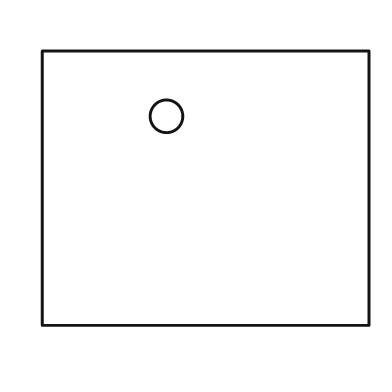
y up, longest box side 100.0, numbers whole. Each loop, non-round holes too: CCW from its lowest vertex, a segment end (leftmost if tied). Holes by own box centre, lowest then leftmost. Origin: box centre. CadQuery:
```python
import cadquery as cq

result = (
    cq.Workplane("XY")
    .moveTo(-50.0, -42.0)
    .lineTo(50.0, -42.0)
    .lineTo(50.0, 42.0)
    .lineTo(-50.0, 42.0)
    .close()
    .moveTo(-12.0, 22.0)
    .circle(5.0)
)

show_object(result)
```